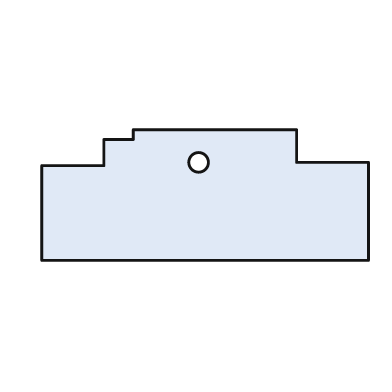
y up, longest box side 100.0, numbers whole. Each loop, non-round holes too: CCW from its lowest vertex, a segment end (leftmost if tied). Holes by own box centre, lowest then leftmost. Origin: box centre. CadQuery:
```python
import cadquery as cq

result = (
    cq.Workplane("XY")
    .moveTo(-50.0, -20.0)
    .lineTo(50.0, -20.0)
    .lineTo(50.0, 10.0)
    .lineTo(28.0, 10.0)
    .lineTo(28.0, 20.0)
    .lineTo(-22.0, 20.0)
    .lineTo(-22.0, 17.0)
    .lineTo(-31.0, 17.0)
    .lineTo(-31.0, 9.0)
    .lineTo(-50.0, 9.0)
    .close()
    .moveTo(-2.0, 10.0)
    .circle(3.0)
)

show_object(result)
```